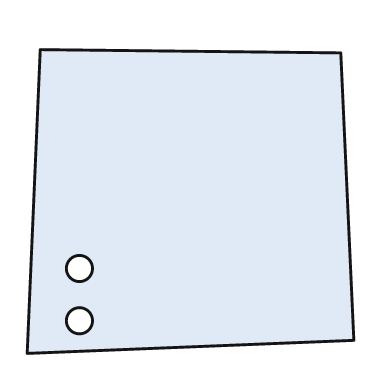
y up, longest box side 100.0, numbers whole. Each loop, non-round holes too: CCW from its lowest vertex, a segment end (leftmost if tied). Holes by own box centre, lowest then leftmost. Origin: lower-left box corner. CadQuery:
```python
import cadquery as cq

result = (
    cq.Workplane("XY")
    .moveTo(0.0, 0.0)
    .lineTo(100.0, 4.0)
    .lineTo(96.0, 92.0)
    .lineTo(4.0, 93.0)
    .close()
    .moveTo(16.0, 10.0)
    .circle(4.0)
    .moveTo(16.0, 26.0)
    .circle(4.0)
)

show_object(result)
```